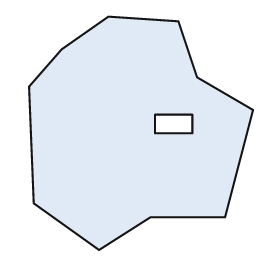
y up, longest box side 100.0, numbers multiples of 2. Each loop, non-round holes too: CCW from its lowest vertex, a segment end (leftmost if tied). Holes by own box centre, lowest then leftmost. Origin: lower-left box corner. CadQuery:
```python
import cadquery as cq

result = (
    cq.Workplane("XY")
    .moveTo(30.0, 0.0)
    .lineTo(52.0, 14.0)
    .lineTo(84.0, 14.0)
    .lineTo(96.0, 60.0)
    .lineTo(72.0, 74.0)
    .lineTo(64.0, 98.0)
    .lineTo(34.0, 100.0)
    .lineTo(14.0, 86.0)
    .lineTo(0.0, 70.0)
    .lineTo(2.0, 20.0)
    .close()
    .moveTo(54.0, 50.0)
    .lineTo(70.0, 50.0)
    .lineTo(70.0, 58.0)
    .lineTo(54.0, 58.0)
    .close()
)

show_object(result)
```